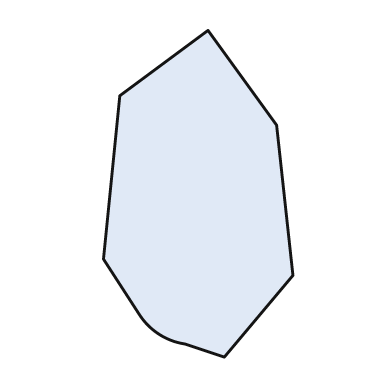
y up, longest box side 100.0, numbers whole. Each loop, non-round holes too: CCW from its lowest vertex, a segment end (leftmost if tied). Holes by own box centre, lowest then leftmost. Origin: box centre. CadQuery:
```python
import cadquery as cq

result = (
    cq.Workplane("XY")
    .moveTo(8.0, -50.0)
    .lineTo(29.0, -25.0)
    .lineTo(24.0, 21.0)
    .lineTo(3.0, 50.0)
    .lineTo(-24.0, 30.0)
    .lineTo(-29.0, -20.0)
    .lineTo(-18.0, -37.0)
    .threePointArc((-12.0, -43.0), (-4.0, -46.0))
    .close()
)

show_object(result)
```